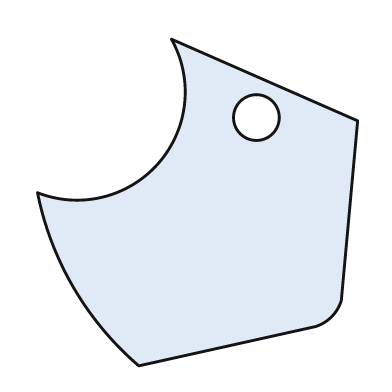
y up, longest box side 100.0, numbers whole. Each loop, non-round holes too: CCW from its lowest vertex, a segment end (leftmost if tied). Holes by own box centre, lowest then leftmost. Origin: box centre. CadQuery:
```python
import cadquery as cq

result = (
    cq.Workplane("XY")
    .moveTo(-18.0, -50.0)
    .lineTo(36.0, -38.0)
    .threePointArc((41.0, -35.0), (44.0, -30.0))
    .lineTo(49.0, 25.0)
    .lineTo(-8.0, 50.0)
    .threePointArc((-12.0, 12.0), (-49.0, 3.0))
    .threePointArc((-38.0, -26.0), (-18.0, -50.0))
    .close()
    .moveTo(18.0, 26.0)
    .circle(7.0)
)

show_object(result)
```